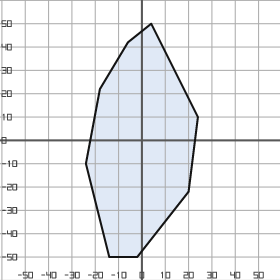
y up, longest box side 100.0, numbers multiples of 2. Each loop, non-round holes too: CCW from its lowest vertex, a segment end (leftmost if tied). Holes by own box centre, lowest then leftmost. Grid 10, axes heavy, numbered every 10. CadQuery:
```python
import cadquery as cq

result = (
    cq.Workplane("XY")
    .moveTo(-14.0, -50.0)
    .lineTo(-2.0, -50.0)
    .lineTo(20.0, -22.0)
    .lineTo(24.0, 10.0)
    .lineTo(4.0, 50.0)
    .lineTo(-6.0, 42.0)
    .lineTo(-18.0, 22.0)
    .lineTo(-24.0, -10.0)
    .close()
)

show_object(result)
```